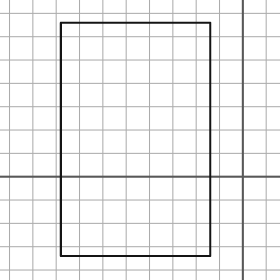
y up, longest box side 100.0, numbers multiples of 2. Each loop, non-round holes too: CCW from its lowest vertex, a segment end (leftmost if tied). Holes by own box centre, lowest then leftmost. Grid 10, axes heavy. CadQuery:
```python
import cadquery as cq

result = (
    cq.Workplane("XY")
    .moveTo(-78.0, -34.0)
    .lineTo(-14.0, -34.0)
    .lineTo(-14.0, 66.0)
    .lineTo(-78.0, 66.0)
    .close()
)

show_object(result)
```